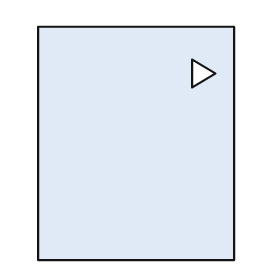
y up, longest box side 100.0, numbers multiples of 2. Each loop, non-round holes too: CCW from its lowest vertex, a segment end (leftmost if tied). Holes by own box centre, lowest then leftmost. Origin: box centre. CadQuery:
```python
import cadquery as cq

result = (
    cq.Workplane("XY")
    .moveTo(-42.0, -50.0)
    .lineTo(42.0, -50.0)
    .lineTo(42.0, 50.0)
    .lineTo(-42.0, 50.0)
    .close()
    .moveTo(24.0, 24.0)
    .lineTo(34.0, 30.0)
    .lineTo(24.0, 36.0)
    .close()
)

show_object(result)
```